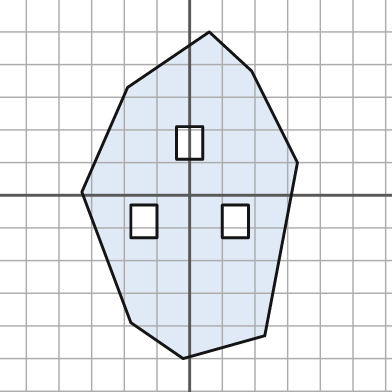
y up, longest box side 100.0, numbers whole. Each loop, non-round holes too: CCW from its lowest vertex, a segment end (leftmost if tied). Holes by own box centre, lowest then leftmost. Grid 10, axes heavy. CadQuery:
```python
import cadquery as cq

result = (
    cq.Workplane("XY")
    .moveTo(-2.0, -50.0)
    .lineTo(23.0, -43.0)
    .lineTo(33.0, 10.0)
    .lineTo(19.0, 38.0)
    .lineTo(6.0, 50.0)
    .lineTo(-19.0, 33.0)
    .lineTo(-33.0, 1.0)
    .lineTo(-18.0, -39.0)
    .close()
    .moveTo(-18.0, -13.0)
    .lineTo(-10.0, -13.0)
    .lineTo(-10.0, -3.0)
    .lineTo(-18.0, -3.0)
    .close()
    .moveTo(10.0, -13.0)
    .lineTo(18.0, -13.0)
    .lineTo(18.0, -3.0)
    .lineTo(10.0, -3.0)
    .close()
    .moveTo(-4.0, 11.0)
    .lineTo(4.0, 11.0)
    .lineTo(4.0, 21.0)
    .lineTo(-4.0, 21.0)
    .close()
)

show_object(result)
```